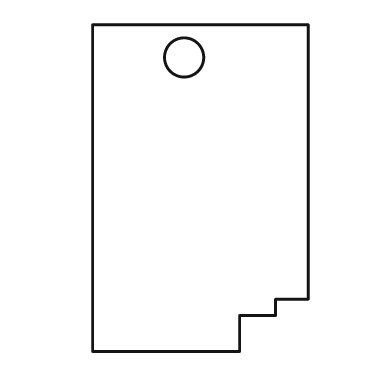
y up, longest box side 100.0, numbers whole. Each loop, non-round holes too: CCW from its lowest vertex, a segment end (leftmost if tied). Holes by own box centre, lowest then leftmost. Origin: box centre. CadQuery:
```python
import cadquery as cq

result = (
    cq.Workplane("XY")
    .moveTo(-33.0, -50.0)
    .lineTo(12.0, -50.0)
    .lineTo(12.0, -39.0)
    .lineTo(23.0, -39.0)
    .lineTo(23.0, -34.0)
    .lineTo(33.0, -34.0)
    .lineTo(33.0, 50.0)
    .lineTo(-33.0, 50.0)
    .close()
    .moveTo(-5.0, 40.0)
    .circle(6.0)
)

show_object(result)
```